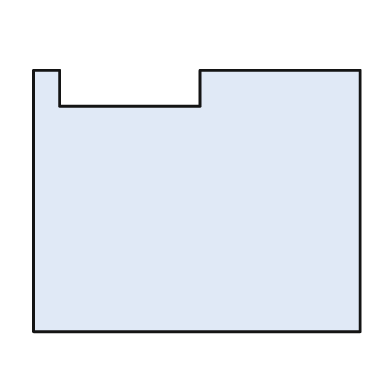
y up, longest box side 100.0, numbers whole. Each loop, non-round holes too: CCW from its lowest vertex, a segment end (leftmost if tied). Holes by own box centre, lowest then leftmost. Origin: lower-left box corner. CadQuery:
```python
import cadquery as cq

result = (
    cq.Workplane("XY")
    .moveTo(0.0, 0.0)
    .lineTo(100.0, 0.0)
    .lineTo(100.0, 80.0)
    .lineTo(51.0, 80.0)
    .lineTo(51.0, 69.0)
    .lineTo(8.0, 69.0)
    .lineTo(8.0, 80.0)
    .lineTo(0.0, 80.0)
    .close()
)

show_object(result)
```